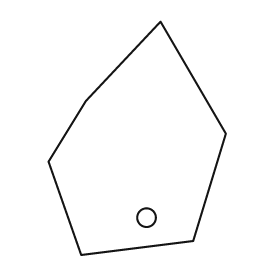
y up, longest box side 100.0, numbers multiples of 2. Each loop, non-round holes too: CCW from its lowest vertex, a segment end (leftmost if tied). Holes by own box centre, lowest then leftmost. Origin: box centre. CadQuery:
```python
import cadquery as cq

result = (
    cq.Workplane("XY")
    .moveTo(-24.0, -50.0)
    .lineTo(24.0, -44.0)
    .lineTo(38.0, 2.0)
    .lineTo(10.0, 50.0)
    .lineTo(-22.0, 16.0)
    .lineTo(-38.0, -10.0)
    .close()
    .moveTo(4.0, -34.0)
    .circle(4.0)
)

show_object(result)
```